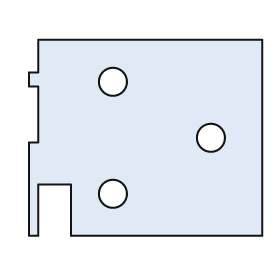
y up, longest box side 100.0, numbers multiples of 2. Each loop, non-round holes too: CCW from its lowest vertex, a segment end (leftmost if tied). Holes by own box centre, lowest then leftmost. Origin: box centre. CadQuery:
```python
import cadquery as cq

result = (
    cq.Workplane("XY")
    .moveTo(-50.0, -42.0)
    .lineTo(-46.0, -42.0)
    .lineTo(-46.0, -20.0)
    .lineTo(-32.0, -20.0)
    .lineTo(-32.0, -42.0)
    .lineTo(50.0, -42.0)
    .lineTo(50.0, 42.0)
    .lineTo(-46.0, 42.0)
    .lineTo(-46.0, 28.0)
    .lineTo(-50.0, 28.0)
    .lineTo(-50.0, 22.0)
    .lineTo(-46.0, 22.0)
    .lineTo(-46.0, -2.0)
    .lineTo(-50.0, -2.0)
    .close()
    .moveTo(-14.0, -24.0)
    .circle(6.0)
    .moveTo(28.0, 0.0)
    .circle(6.0)
    .moveTo(-14.0, 24.0)
    .circle(6.0)
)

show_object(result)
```